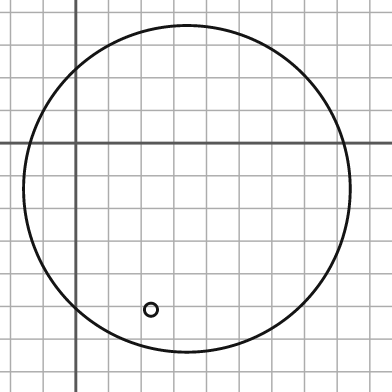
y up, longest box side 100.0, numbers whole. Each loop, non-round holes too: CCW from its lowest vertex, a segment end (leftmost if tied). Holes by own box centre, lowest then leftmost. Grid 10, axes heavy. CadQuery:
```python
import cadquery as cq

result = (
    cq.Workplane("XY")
    .moveTo(34.0, -14.0)
    .circle(50.0)
    .moveTo(23.0, -51.0)
    .circle(2.0)
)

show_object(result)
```